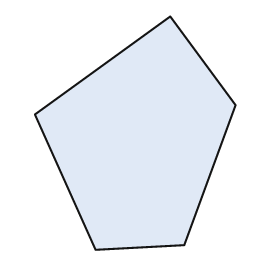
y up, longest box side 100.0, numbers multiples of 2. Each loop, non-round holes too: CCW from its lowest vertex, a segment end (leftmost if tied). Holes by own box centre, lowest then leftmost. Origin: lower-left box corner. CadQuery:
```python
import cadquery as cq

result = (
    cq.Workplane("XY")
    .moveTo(26.0, 0.0)
    .lineTo(64.0, 2.0)
    .lineTo(86.0, 62.0)
    .lineTo(58.0, 100.0)
    .lineTo(0.0, 58.0)
    .close()
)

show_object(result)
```